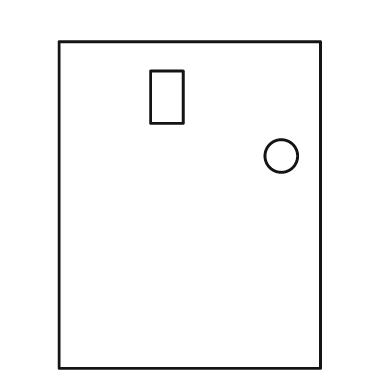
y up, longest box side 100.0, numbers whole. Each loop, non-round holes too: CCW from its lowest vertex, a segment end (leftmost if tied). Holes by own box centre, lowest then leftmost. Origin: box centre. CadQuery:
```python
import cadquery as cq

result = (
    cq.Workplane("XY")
    .moveTo(-40.0, -50.0)
    .lineTo(40.0, -50.0)
    .lineTo(40.0, 50.0)
    .lineTo(-40.0, 50.0)
    .close()
    .moveTo(28.0, 15.0)
    .circle(5.0)
    .moveTo(-12.0, 25.0)
    .lineTo(-2.0, 25.0)
    .lineTo(-2.0, 41.0)
    .lineTo(-12.0, 41.0)
    .close()
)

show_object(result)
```